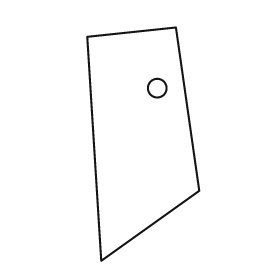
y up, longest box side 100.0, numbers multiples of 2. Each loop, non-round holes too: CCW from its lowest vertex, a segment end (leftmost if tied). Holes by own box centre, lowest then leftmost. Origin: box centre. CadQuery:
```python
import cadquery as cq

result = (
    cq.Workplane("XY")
    .moveTo(-18.0, -50.0)
    .lineTo(24.0, -20.0)
    .lineTo(14.0, 50.0)
    .lineTo(-24.0, 46.0)
    .close()
    .moveTo(6.0, 24.0)
    .circle(4.0)
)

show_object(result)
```